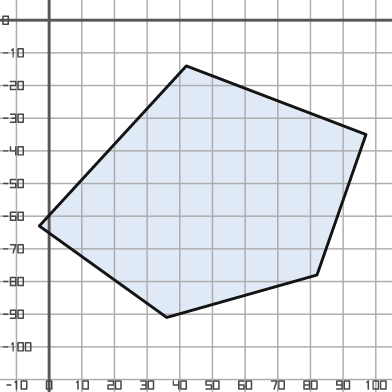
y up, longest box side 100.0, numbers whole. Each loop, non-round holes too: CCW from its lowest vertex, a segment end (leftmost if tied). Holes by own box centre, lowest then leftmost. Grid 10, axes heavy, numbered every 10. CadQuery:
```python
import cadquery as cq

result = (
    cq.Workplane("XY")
    .moveTo(36.0, -91.0)
    .lineTo(82.0, -78.0)
    .lineTo(97.0, -35.0)
    .lineTo(42.0, -14.0)
    .lineTo(-3.0, -63.0)
    .close()
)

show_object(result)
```